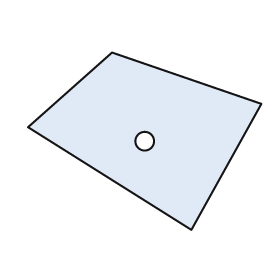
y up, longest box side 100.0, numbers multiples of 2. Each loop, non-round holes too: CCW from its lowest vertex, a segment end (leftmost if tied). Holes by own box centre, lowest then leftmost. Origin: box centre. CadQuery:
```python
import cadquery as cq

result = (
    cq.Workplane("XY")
    .moveTo(20.0, -38.0)
    .lineTo(50.0, 16.0)
    .lineTo(-14.0, 38.0)
    .lineTo(-50.0, 6.0)
    .close()
    .moveTo(0.0, 0.0)
    .circle(4.0)
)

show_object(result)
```